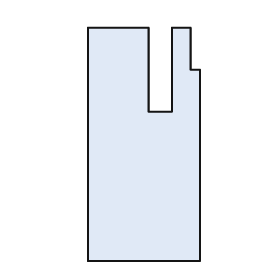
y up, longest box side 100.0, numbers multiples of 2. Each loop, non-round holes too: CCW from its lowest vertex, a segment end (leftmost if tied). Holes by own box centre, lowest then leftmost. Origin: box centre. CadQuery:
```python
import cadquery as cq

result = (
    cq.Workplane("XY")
    .moveTo(-24.0, -50.0)
    .lineTo(24.0, -50.0)
    .lineTo(24.0, 32.0)
    .lineTo(20.0, 32.0)
    .lineTo(20.0, 50.0)
    .lineTo(12.0, 50.0)
    .lineTo(12.0, 14.0)
    .lineTo(2.0, 14.0)
    .lineTo(2.0, 50.0)
    .lineTo(-24.0, 50.0)
    .close()
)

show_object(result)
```